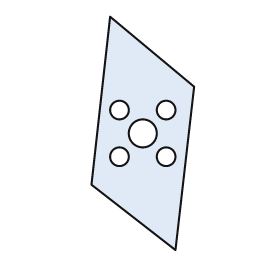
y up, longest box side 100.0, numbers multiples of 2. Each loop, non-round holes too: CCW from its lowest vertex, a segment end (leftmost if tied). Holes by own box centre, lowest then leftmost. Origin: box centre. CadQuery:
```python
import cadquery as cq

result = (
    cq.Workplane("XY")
    .moveTo(14.0, -50.0)
    .lineTo(22.0, 20.0)
    .lineTo(-14.0, 50.0)
    .lineTo(-22.0, -22.0)
    .close()
    .moveTo(-10.0, -10.0)
    .circle(4.0)
    .moveTo(10.0, -10.0)
    .circle(4.0)
    .moveTo(0.0, 0.0)
    .circle(6.0)
    .moveTo(-10.0, 10.0)
    .circle(4.0)
    .moveTo(10.0, 10.0)
    .circle(4.0)
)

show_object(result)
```